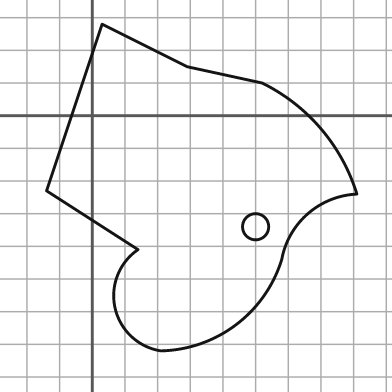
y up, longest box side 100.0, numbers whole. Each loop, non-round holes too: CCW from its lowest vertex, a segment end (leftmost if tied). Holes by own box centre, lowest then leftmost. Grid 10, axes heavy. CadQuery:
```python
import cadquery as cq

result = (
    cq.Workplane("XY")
    .moveTo(21.0, -72.0)
    .threePointArc((44.0, -64.0), (58.0, -44.0))
    .threePointArc((66.0, -30.0), (81.0, -24.0))
    .threePointArc((70.0, -4.0), (52.0, 10.0))
    .lineTo(29.0, 15.0)
    .lineTo(3.0, 28.0)
    .lineTo(-14.0, -23.0)
    .lineTo(14.0, -41.0)
    .threePointArc((7.0, -59.0), (21.0, -72.0))
    .close()
    .moveTo(50.0, -34.0)
    .circle(4.0)
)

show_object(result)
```